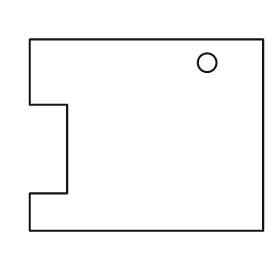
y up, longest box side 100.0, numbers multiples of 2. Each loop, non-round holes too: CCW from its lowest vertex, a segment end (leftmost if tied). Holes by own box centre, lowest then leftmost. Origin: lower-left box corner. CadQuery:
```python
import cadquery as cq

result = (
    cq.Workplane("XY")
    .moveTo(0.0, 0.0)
    .lineTo(100.0, 0.0)
    .lineTo(100.0, 82.0)
    .lineTo(0.0, 82.0)
    .lineTo(0.0, 54.0)
    .lineTo(16.0, 54.0)
    .lineTo(16.0, 16.0)
    .lineTo(0.0, 16.0)
    .close()
    .moveTo(76.0, 72.0)
    .circle(4.0)
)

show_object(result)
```